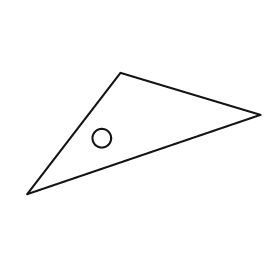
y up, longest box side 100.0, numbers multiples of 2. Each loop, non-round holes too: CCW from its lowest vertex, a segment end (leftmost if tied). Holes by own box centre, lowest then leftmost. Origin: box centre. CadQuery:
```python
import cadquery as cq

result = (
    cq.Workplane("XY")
    .moveTo(-50.0, -26.0)
    .lineTo(50.0, 8.0)
    .lineTo(-10.0, 26.0)
    .close()
    .moveTo(-18.0, -2.0)
    .circle(4.0)
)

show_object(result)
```